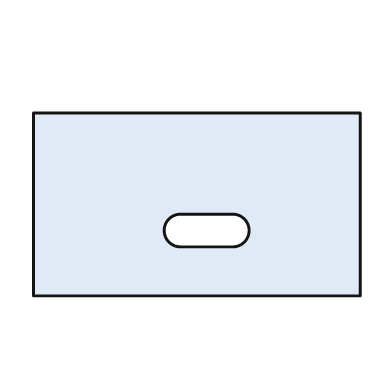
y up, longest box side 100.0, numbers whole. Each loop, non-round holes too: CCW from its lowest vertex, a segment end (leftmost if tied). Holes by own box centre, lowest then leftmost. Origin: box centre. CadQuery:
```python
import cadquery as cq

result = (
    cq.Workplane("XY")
    .moveTo(-50.0, -28.0)
    .lineTo(50.0, -28.0)
    .lineTo(50.0, 28.0)
    .lineTo(-50.0, 28.0)
    .close()
    .moveTo(-5.0, -13.0)
    .lineTo(11.0, -13.0)
    .threePointArc((16.0, -8.0), (11.0, -3.0))
    .lineTo(-5.0, -3.0)
    .threePointArc((-10.0, -8.0), (-5.0, -13.0))
    .close()
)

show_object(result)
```